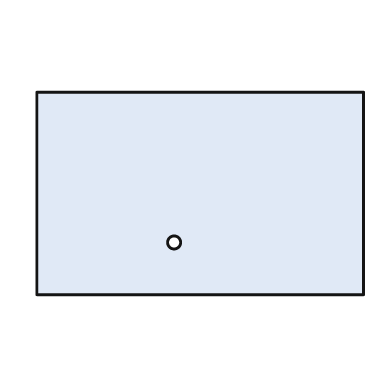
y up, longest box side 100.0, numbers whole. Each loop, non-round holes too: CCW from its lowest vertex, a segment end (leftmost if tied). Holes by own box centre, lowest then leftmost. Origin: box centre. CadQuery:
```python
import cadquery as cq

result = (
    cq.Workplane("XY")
    .moveTo(-50.0, -31.0)
    .lineTo(50.0, -31.0)
    .lineTo(50.0, 31.0)
    .lineTo(-50.0, 31.0)
    .close()
    .moveTo(-8.0, -15.0)
    .circle(2.0)
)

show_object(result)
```